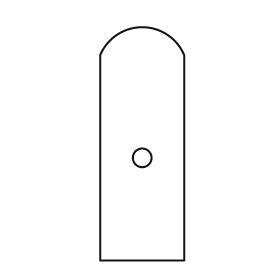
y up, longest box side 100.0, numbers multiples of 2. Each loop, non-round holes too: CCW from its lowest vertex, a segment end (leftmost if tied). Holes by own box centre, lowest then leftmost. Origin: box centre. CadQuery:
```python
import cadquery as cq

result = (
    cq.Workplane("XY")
    .moveTo(-18.0, -50.0)
    .lineTo(18.0, -50.0)
    .lineTo(18.0, 38.0)
    .threePointArc((0.0, 50.0), (-18.0, 38.0))
    .close()
    .moveTo(0.0, -6.0)
    .circle(4.0)
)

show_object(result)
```